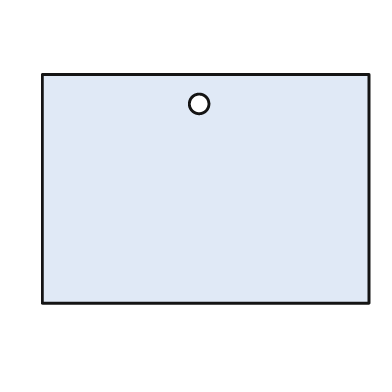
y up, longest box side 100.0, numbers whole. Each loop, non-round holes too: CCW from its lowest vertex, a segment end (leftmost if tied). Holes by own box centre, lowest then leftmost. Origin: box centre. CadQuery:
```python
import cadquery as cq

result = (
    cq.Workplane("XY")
    .moveTo(-50.0, -35.0)
    .lineTo(50.0, -35.0)
    .lineTo(50.0, 35.0)
    .lineTo(-50.0, 35.0)
    .close()
    .moveTo(-2.0, 26.0)
    .circle(3.0)
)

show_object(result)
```